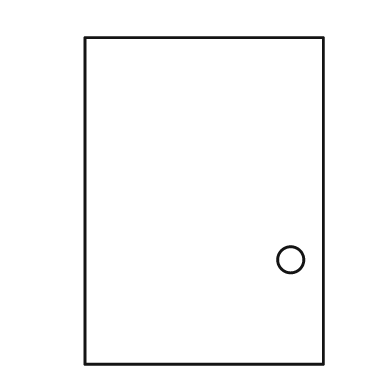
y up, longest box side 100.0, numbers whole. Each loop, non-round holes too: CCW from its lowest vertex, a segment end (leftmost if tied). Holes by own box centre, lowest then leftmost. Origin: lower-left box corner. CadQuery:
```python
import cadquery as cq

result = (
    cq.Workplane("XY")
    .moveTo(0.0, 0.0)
    .lineTo(73.0, 0.0)
    .lineTo(73.0, 100.0)
    .lineTo(0.0, 100.0)
    .close()
    .moveTo(63.0, 32.0)
    .circle(4.0)
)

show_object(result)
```